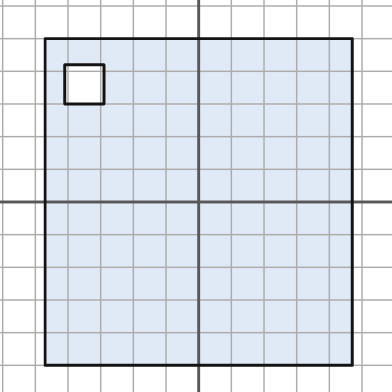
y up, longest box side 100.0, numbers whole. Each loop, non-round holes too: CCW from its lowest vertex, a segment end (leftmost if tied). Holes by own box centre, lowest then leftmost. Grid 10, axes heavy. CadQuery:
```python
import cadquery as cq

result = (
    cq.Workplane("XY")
    .moveTo(-47.0, -50.0)
    .lineTo(47.0, -50.0)
    .lineTo(47.0, 50.0)
    .lineTo(-47.0, 50.0)
    .close()
    .moveTo(-41.0, 30.0)
    .lineTo(-29.0, 30.0)
    .lineTo(-29.0, 42.0)
    .lineTo(-41.0, 42.0)
    .close()
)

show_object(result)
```